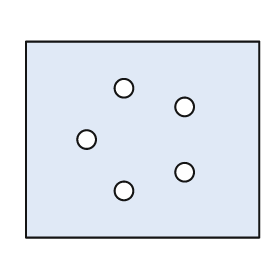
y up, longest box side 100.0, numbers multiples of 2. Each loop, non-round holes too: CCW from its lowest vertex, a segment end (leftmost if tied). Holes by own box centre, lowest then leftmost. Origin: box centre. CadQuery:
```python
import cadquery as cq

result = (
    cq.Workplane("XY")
    .moveTo(-50.0, -42.0)
    .lineTo(50.0, -42.0)
    .lineTo(50.0, 42.0)
    .lineTo(-50.0, 42.0)
    .close()
    .moveTo(-8.0, -22.0)
    .circle(4.0)
    .moveTo(18.0, -14.0)
    .circle(4.0)
    .moveTo(-24.0, 0.0)
    .circle(4.0)
    .moveTo(18.0, 14.0)
    .circle(4.0)
    .moveTo(-8.0, 22.0)
    .circle(4.0)
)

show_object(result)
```